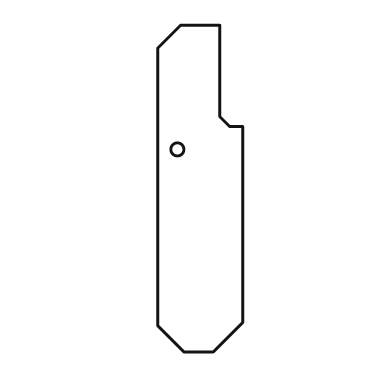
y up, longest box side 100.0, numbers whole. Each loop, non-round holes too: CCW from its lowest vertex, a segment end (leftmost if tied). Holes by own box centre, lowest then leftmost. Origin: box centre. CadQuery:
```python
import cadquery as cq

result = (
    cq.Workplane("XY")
    .moveTo(-5.0, -50.0)
    .lineTo(4.0, -50.0)
    .lineTo(13.0, -41.0)
    .lineTo(13.0, 19.0)
    .lineTo(9.0, 19.0)
    .lineTo(6.0, 22.0)
    .lineTo(6.0, 50.0)
    .lineTo(-6.0, 50.0)
    .lineTo(-13.0, 43.0)
    .lineTo(-13.0, -42.0)
    .close()
    .moveTo(-7.0, 12.0)
    .circle(2.0)
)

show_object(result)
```